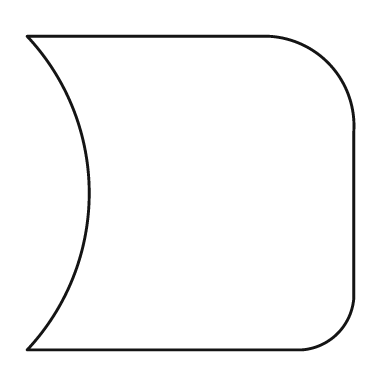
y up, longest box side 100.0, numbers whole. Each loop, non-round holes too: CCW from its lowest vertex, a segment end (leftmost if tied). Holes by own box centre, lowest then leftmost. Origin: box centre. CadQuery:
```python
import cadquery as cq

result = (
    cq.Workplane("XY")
    .moveTo(-50.0, -48.0)
    .lineTo(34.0, -48.0)
    .threePointArc((45.0, -43.0), (50.0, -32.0))
    .lineTo(50.0, 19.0)
    .threePointArc((42.0, 40.0), (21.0, 48.0))
    .lineTo(-50.0, 48.0)
    .threePointArc((-31.0, 0.0), (-50.0, -48.0))
    .close()
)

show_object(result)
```